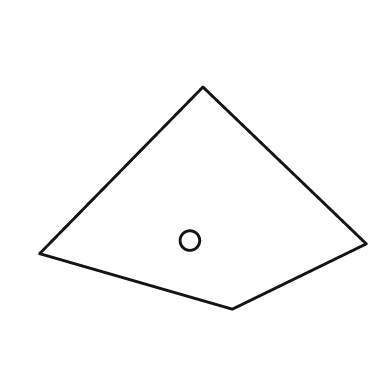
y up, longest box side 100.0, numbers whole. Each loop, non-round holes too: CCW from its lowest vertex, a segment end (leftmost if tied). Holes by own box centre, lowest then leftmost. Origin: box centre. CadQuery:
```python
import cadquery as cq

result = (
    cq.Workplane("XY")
    .moveTo(9.0, -34.0)
    .lineTo(50.0, -14.0)
    .lineTo(0.0, 34.0)
    .lineTo(-50.0, -17.0)
    .close()
    .moveTo(-4.0, -13.0)
    .circle(3.0)
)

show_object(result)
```